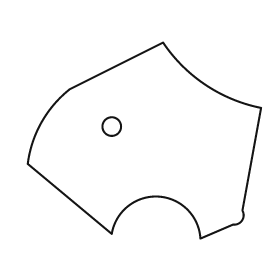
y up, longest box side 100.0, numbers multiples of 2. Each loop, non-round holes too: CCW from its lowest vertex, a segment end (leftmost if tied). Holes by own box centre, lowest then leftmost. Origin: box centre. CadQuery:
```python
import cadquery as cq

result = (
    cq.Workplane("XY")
    .moveTo(24.0, -42.0)
    .lineTo(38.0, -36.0)
    .threePointArc((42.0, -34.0), (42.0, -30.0))
    .lineTo(50.0, 14.0)
    .threePointArc((26.0, 24.0), (8.0, 42.0))
    .lineTo(-32.0, 22.0)
    .threePointArc((-44.0, 8.0), (-50.0, -10.0))
    .lineTo(-14.0, -40.0)
    .threePointArc((6.0, -24.0), (24.0, -42.0))
    .close()
    .moveTo(-14.0, 6.0)
    .circle(4.0)
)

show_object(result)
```